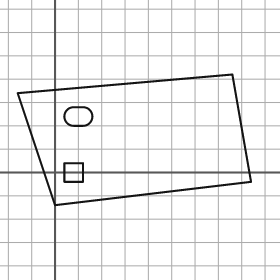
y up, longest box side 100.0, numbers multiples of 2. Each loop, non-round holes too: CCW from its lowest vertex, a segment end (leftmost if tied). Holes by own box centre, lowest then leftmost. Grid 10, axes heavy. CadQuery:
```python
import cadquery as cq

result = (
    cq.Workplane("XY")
    .moveTo(0.0, -14.0)
    .lineTo(84.0, -4.0)
    .lineTo(76.0, 42.0)
    .lineTo(-16.0, 34.0)
    .close()
    .moveTo(4.0, -4.0)
    .lineTo(12.0, -4.0)
    .lineTo(12.0, 4.0)
    .lineTo(4.0, 4.0)
    .close()
    .moveTo(8.0, 20.0)
    .lineTo(12.0, 20.0)
    .threePointArc((16.0, 24.0), (12.0, 28.0))
    .lineTo(8.0, 28.0)
    .threePointArc((4.0, 24.0), (8.0, 20.0))
    .close()
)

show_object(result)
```